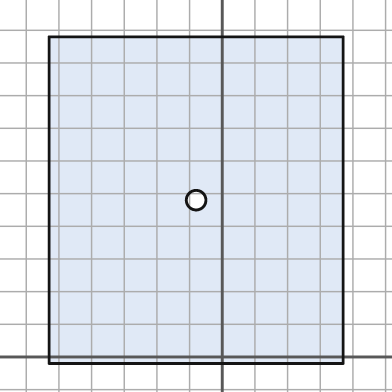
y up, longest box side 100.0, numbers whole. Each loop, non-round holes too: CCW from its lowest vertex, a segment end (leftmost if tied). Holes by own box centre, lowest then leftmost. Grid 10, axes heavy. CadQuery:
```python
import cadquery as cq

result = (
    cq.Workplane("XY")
    .moveTo(-53.0, -2.0)
    .lineTo(37.0, -2.0)
    .lineTo(37.0, 98.0)
    .lineTo(-53.0, 98.0)
    .close()
    .moveTo(-8.0, 48.0)
    .circle(3.0)
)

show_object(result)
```